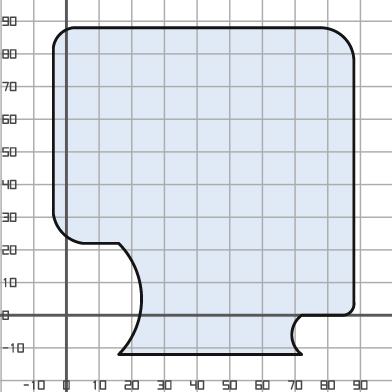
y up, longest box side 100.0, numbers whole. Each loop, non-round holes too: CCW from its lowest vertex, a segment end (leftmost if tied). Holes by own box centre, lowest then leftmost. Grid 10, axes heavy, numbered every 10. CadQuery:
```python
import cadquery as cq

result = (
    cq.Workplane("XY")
    .moveTo(16.0, -12.0)
    .lineTo(72.0, -12.0)
    .threePointArc((69.0, -6.0), (72.0, 0.0))
    .lineTo(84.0, 0.0)
    .threePointArc((87.0, 1.0), (88.0, 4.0))
    .lineTo(88.0, 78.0)
    .threePointArc((85.0, 85.0), (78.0, 88.0))
    .lineTo(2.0, 88.0)
    .threePointArc((-2.0, 86.0), (-4.0, 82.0))
    .lineTo(-4.0, 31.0)
    .threePointArc((-1.0, 25.0), (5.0, 22.0))
    .lineTo(16.0, 22.0)
    .threePointArc((23.0, 5.0), (16.0, -12.0))
    .close()
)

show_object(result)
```